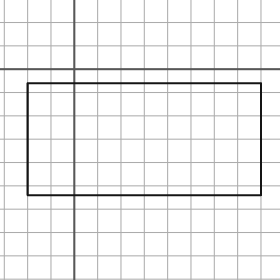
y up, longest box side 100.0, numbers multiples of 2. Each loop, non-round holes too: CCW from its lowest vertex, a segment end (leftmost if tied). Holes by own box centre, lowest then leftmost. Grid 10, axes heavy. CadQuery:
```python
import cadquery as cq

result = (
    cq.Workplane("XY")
    .moveTo(-20.0, -54.0)
    .lineTo(80.0, -54.0)
    .lineTo(80.0, -6.0)
    .lineTo(-20.0, -6.0)
    .close()
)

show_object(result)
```